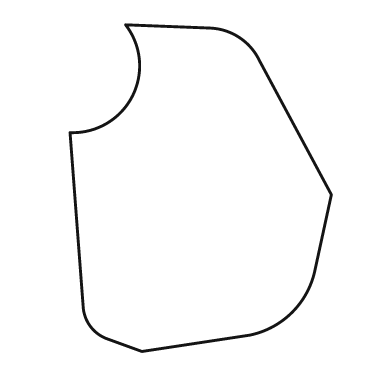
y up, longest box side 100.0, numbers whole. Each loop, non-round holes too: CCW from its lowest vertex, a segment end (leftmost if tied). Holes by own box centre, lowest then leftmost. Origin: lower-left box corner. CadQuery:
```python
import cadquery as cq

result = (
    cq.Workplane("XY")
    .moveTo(22.0, 0.0)
    .lineTo(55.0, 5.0)
    .threePointArc((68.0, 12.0), (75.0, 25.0))
    .lineTo(80.0, 48.0)
    .lineTo(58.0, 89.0)
    .threePointArc((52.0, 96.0), (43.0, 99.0))
    .lineTo(17.0, 100.0)
    .threePointArc((19.0, 78.0), (0.0, 67.0))
    .lineTo(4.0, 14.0)
    .threePointArc((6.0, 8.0), (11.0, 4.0))
    .close()
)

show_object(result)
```